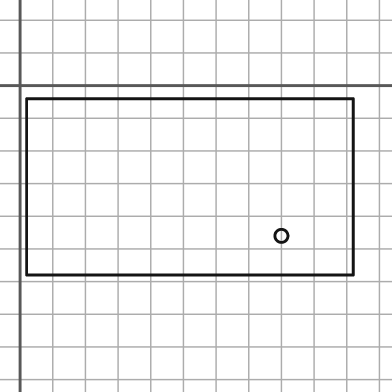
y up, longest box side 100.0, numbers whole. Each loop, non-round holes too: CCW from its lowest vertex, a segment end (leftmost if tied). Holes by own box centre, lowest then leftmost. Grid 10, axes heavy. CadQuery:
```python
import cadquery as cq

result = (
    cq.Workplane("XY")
    .moveTo(2.0, -58.0)
    .lineTo(102.0, -58.0)
    .lineTo(102.0, -4.0)
    .lineTo(2.0, -4.0)
    .close()
    .moveTo(80.0, -46.0)
    .circle(2.0)
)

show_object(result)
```